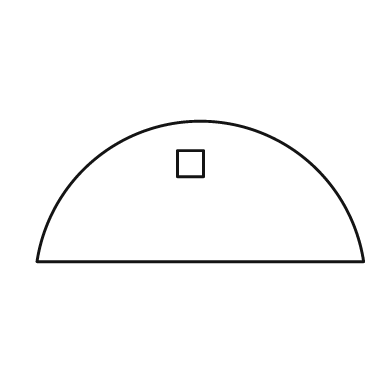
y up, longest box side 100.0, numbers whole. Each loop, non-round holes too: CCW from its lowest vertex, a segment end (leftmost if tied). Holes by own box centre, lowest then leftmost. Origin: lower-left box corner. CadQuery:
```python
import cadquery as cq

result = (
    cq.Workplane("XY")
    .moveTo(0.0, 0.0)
    .lineTo(100.0, 0.0)
    .threePointArc((50.0, 43.0), (0.0, 0.0))
    .close()
    .moveTo(43.0, 26.0)
    .lineTo(51.0, 26.0)
    .lineTo(51.0, 34.0)
    .lineTo(43.0, 34.0)
    .close()
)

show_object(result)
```